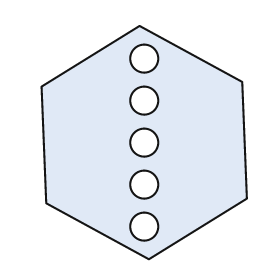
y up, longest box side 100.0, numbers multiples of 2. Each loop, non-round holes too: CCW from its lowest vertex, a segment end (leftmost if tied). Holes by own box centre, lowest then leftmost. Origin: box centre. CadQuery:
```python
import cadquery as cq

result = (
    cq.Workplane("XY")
    .moveTo(2.0, -50.0)
    .lineTo(44.0, -24.0)
    .lineTo(42.0, 26.0)
    .lineTo(-2.0, 50.0)
    .lineTo(-44.0, 24.0)
    .lineTo(-42.0, -26.0)
    .close()
    .moveTo(0.0, -36.0)
    .circle(6.0)
    .moveTo(0.0, -18.0)
    .circle(6.0)
    .moveTo(0.0, 0.0)
    .circle(6.0)
    .moveTo(0.0, 18.0)
    .circle(6.0)
    .moveTo(0.0, 36.0)
    .circle(6.0)
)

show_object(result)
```